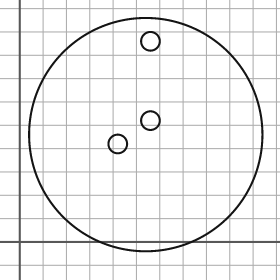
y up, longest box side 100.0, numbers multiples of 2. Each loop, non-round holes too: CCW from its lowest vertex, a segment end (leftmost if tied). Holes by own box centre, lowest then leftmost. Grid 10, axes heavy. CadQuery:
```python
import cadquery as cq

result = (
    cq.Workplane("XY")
    .moveTo(54.0, 46.0)
    .circle(50.0)
    .moveTo(42.0, 42.0)
    .circle(4.0)
    .moveTo(56.0, 52.0)
    .circle(4.0)
    .moveTo(56.0, 86.0)
    .circle(4.0)
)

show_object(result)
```